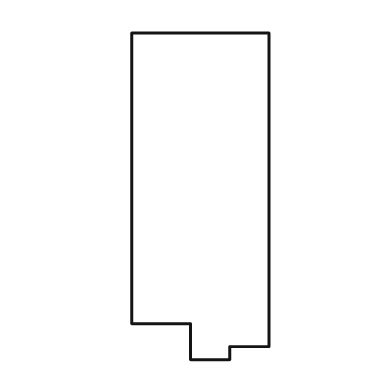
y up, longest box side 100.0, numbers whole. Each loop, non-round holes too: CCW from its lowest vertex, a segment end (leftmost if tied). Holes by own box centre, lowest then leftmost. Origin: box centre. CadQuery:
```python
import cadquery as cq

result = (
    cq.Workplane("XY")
    .moveTo(-3.0, -50.0)
    .lineTo(9.0, -50.0)
    .lineTo(9.0, -46.0)
    .lineTo(21.0, -46.0)
    .lineTo(21.0, 50.0)
    .lineTo(-21.0, 50.0)
    .lineTo(-21.0, -39.0)
    .lineTo(-3.0, -39.0)
    .close()
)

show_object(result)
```